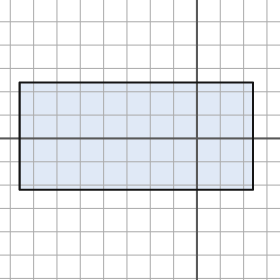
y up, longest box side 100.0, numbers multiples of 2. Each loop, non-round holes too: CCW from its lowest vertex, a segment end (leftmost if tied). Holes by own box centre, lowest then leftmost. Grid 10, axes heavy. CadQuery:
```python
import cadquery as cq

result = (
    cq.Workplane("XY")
    .moveTo(-76.0, -22.0)
    .lineTo(24.0, -22.0)
    .lineTo(24.0, 24.0)
    .lineTo(-76.0, 24.0)
    .close()
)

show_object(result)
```